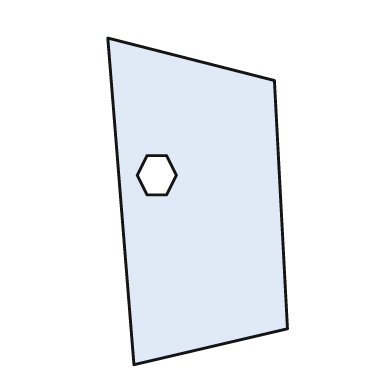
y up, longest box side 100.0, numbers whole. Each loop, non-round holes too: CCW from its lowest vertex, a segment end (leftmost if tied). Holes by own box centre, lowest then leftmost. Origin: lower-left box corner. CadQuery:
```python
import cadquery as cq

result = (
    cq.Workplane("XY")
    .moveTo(8.0, 0.0)
    .lineTo(55.0, 11.0)
    .lineTo(51.0, 87.0)
    .lineTo(0.0, 100.0)
    .close()
    .moveTo(12.0, 52.0)
    .lineTo(18.0, 52.0)
    .lineTo(21.0, 58.0)
    .lineTo(18.0, 64.0)
    .lineTo(12.0, 64.0)
    .lineTo(9.0, 58.0)
    .close()
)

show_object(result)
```